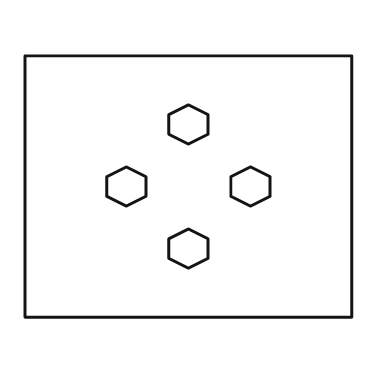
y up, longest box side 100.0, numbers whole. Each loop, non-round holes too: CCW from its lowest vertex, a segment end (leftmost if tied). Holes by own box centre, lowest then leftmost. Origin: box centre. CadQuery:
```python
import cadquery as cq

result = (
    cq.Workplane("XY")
    .moveTo(-50.0, -40.0)
    .lineTo(50.0, -40.0)
    .lineTo(50.0, 40.0)
    .lineTo(-50.0, 40.0)
    .close()
    .moveTo(0.0, -25.0)
    .lineTo(6.0, -22.0)
    .lineTo(6.0, -16.0)
    .lineTo(0.0, -13.0)
    .lineTo(-6.0, -16.0)
    .lineTo(-6.0, -22.0)
    .close()
    .moveTo(-19.0, -6.0)
    .lineTo(-13.0, -3.0)
    .lineTo(-13.0, 3.0)
    .lineTo(-19.0, 6.0)
    .lineTo(-25.0, 3.0)
    .lineTo(-25.0, -3.0)
    .close()
    .moveTo(19.0, -6.0)
    .lineTo(25.0, -3.0)
    .lineTo(25.0, 3.0)
    .lineTo(19.0, 6.0)
    .lineTo(13.0, 3.0)
    .lineTo(13.0, -3.0)
    .close()
    .moveTo(0.0, 13.0)
    .lineTo(6.0, 16.0)
    .lineTo(6.0, 22.0)
    .lineTo(0.0, 25.0)
    .lineTo(-6.0, 22.0)
    .lineTo(-6.0, 16.0)
    .close()
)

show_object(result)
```